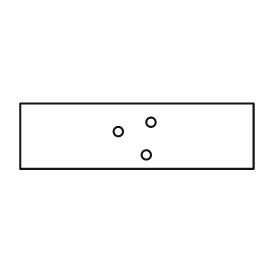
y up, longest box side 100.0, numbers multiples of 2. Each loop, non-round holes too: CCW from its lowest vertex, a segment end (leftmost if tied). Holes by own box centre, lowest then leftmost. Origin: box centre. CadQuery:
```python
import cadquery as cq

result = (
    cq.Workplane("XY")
    .moveTo(-50.0, -14.0)
    .lineTo(50.0, -14.0)
    .lineTo(50.0, 14.0)
    .lineTo(-50.0, 14.0)
    .close()
    .moveTo(4.0, -8.0)
    .circle(2.0)
    .moveTo(-8.0, 2.0)
    .circle(2.0)
    .moveTo(6.0, 6.0)
    .circle(2.0)
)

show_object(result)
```